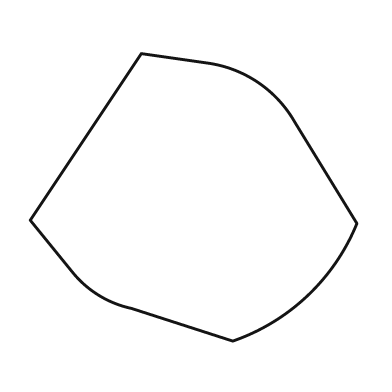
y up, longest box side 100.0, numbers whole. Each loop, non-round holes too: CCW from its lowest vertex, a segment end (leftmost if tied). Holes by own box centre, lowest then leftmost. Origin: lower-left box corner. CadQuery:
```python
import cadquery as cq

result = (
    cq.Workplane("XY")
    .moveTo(62.0, 0.0)
    .threePointArc((85.0, 14.0), (100.0, 36.0))
    .lineTo(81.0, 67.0)
    .threePointArc((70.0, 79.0), (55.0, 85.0))
    .lineTo(34.0, 88.0)
    .lineTo(0.0, 37.0)
    .lineTo(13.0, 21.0)
    .threePointArc((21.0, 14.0), (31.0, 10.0))
    .close()
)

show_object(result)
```